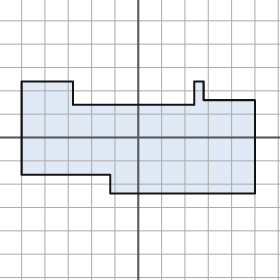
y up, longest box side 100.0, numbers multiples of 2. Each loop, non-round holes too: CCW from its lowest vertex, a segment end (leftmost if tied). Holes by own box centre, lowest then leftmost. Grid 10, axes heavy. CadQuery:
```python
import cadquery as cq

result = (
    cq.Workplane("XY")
    .moveTo(-12.0, -24.0)
    .lineTo(50.0, -24.0)
    .lineTo(50.0, 16.0)
    .lineTo(28.0, 16.0)
    .lineTo(28.0, 24.0)
    .lineTo(24.0, 24.0)
    .lineTo(24.0, 14.0)
    .lineTo(-28.0, 14.0)
    .lineTo(-28.0, 24.0)
    .lineTo(-50.0, 24.0)
    .lineTo(-50.0, -16.0)
    .lineTo(-12.0, -16.0)
    .close()
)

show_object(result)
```